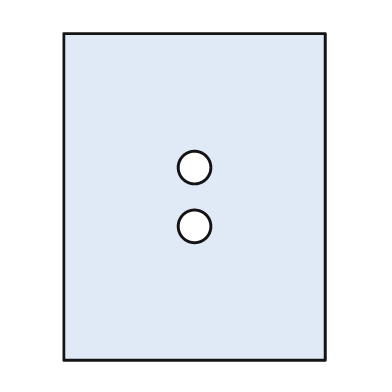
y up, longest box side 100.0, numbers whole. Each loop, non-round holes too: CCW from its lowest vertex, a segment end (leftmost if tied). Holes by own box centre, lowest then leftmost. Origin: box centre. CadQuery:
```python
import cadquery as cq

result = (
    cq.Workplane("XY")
    .moveTo(-40.0, -50.0)
    .lineTo(40.0, -50.0)
    .lineTo(40.0, 50.0)
    .lineTo(-40.0, 50.0)
    .close()
    .moveTo(0.0, -9.0)
    .circle(5.0)
    .moveTo(0.0, 9.0)
    .circle(5.0)
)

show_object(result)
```